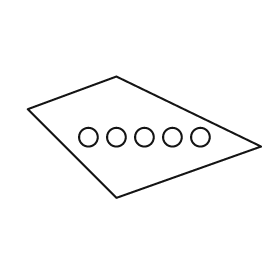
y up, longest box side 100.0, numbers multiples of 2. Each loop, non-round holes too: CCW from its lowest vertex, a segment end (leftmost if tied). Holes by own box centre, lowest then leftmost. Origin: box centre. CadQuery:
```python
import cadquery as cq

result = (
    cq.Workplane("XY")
    .moveTo(-12.0, -26.0)
    .lineTo(50.0, -4.0)
    .lineTo(-12.0, 26.0)
    .lineTo(-50.0, 12.0)
    .close()
    .moveTo(-24.0, 0.0)
    .circle(4.0)
    .moveTo(-12.0, 0.0)
    .circle(4.0)
    .moveTo(0.0, 0.0)
    .circle(4.0)
    .moveTo(12.0, 0.0)
    .circle(4.0)
    .moveTo(24.0, 0.0)
    .circle(4.0)
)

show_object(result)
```